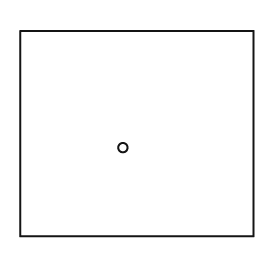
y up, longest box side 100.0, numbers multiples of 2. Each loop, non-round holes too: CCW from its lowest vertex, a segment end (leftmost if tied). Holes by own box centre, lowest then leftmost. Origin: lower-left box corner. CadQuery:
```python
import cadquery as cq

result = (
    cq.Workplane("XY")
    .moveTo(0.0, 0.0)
    .lineTo(100.0, 0.0)
    .lineTo(100.0, 88.0)
    .lineTo(0.0, 88.0)
    .close()
    .moveTo(44.0, 38.0)
    .circle(2.0)
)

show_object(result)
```